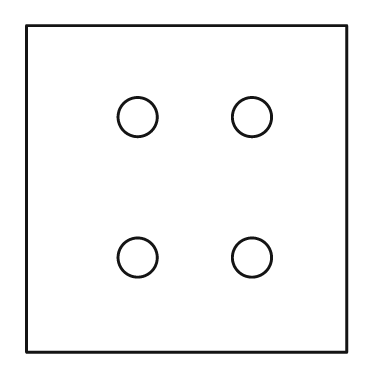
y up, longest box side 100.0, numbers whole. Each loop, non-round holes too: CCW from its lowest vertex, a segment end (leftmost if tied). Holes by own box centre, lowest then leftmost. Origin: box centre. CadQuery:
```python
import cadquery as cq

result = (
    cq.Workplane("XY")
    .moveTo(-49.0, -50.0)
    .lineTo(49.0, -50.0)
    .lineTo(49.0, 50.0)
    .lineTo(-49.0, 50.0)
    .close()
    .moveTo(-15.0, -21.0)
    .circle(6.0)
    .moveTo(20.0, -21.0)
    .circle(6.0)
    .moveTo(-15.0, 22.0)
    .circle(6.0)
    .moveTo(20.0, 22.0)
    .circle(6.0)
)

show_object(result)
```